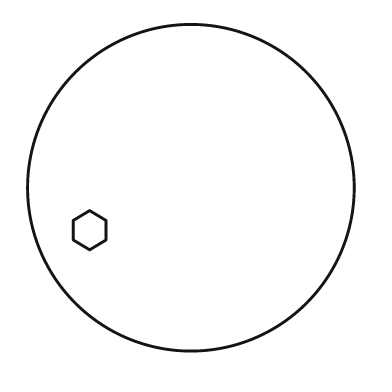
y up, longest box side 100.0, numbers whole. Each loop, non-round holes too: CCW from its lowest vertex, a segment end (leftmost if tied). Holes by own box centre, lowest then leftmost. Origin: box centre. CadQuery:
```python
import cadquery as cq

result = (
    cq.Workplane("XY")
    .moveTo(0.0, 0.0)
    .circle(50.0)
    .moveTo(-31.0, -19.0)
    .lineTo(-26.0, -16.0)
    .lineTo(-26.0, -10.0)
    .lineTo(-31.0, -7.0)
    .lineTo(-36.0, -10.0)
    .lineTo(-36.0, -16.0)
    .close()
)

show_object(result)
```